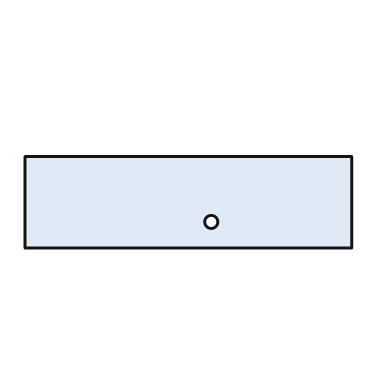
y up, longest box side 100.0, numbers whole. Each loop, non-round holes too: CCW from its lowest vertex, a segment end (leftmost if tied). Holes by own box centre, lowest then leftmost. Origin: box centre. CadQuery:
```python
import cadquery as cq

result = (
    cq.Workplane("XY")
    .moveTo(-50.0, -14.0)
    .lineTo(50.0, -14.0)
    .lineTo(50.0, 14.0)
    .lineTo(-50.0, 14.0)
    .close()
    .moveTo(7.0, -6.0)
    .circle(2.0)
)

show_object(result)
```